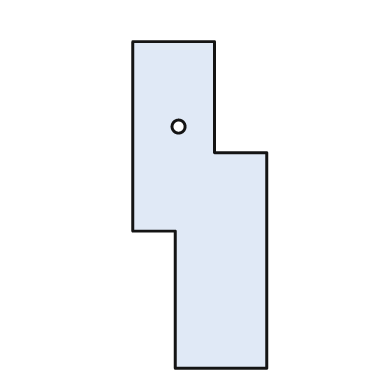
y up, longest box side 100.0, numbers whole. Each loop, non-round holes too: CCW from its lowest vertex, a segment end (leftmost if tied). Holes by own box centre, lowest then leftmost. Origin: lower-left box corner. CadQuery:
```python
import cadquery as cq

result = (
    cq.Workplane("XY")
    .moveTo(13.0, 0.0)
    .lineTo(41.0, 0.0)
    .lineTo(41.0, 66.0)
    .lineTo(25.0, 66.0)
    .lineTo(25.0, 100.0)
    .lineTo(0.0, 100.0)
    .lineTo(0.0, 42.0)
    .lineTo(13.0, 42.0)
    .close()
    .moveTo(14.0, 74.0)
    .circle(2.0)
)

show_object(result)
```